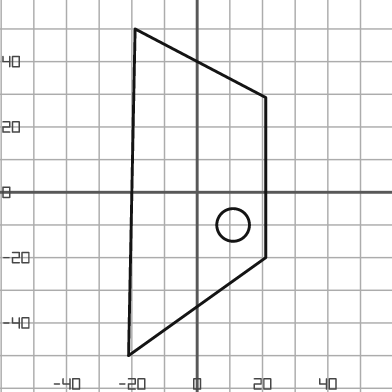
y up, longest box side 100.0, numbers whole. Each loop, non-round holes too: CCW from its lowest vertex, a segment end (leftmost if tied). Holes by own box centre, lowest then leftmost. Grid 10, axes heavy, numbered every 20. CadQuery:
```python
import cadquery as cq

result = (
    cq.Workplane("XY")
    .moveTo(-21.0, -50.0)
    .lineTo(21.0, -20.0)
    .lineTo(21.0, 29.0)
    .lineTo(-19.0, 50.0)
    .close()
    .moveTo(11.0, -10.0)
    .circle(5.0)
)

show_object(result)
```